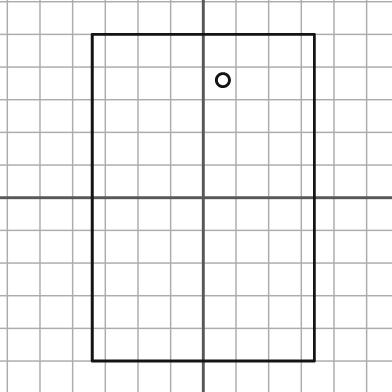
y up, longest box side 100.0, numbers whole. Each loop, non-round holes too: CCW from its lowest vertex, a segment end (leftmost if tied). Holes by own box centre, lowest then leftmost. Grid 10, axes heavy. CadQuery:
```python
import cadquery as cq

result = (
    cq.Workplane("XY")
    .moveTo(-34.0, -50.0)
    .lineTo(34.0, -50.0)
    .lineTo(34.0, 50.0)
    .lineTo(-34.0, 50.0)
    .close()
    .moveTo(6.0, 36.0)
    .circle(2.0)
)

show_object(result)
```